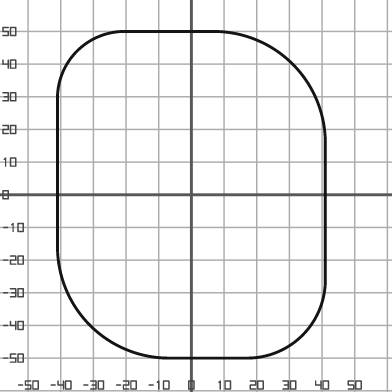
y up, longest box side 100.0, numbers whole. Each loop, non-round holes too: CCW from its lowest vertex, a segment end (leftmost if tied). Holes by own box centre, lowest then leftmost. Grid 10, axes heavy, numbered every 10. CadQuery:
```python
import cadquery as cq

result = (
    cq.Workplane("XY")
    .moveTo(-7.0, -50.0)
    .lineTo(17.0, -50.0)
    .threePointArc((34.0, -43.0), (41.0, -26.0))
    .lineTo(41.0, 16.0)
    .threePointArc((31.0, 40.0), (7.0, 50.0))
    .lineTo(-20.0, 50.0)
    .threePointArc((-35.0, 44.0), (-41.0, 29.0))
    .lineTo(-41.0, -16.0)
    .threePointArc((-31.0, -40.0), (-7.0, -50.0))
    .close()
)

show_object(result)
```